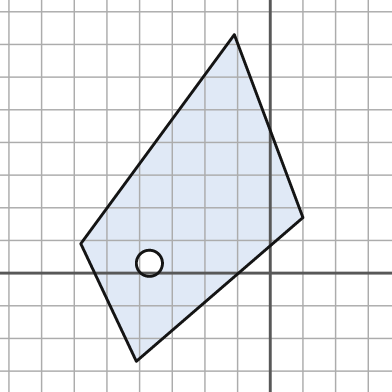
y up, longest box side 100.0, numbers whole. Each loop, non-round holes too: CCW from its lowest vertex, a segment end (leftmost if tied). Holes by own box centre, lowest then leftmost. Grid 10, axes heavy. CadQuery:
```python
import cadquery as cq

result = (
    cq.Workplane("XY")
    .moveTo(-41.0, -27.0)
    .lineTo(10.0, 17.0)
    .lineTo(-11.0, 73.0)
    .lineTo(-58.0, 9.0)
    .close()
    .moveTo(-37.0, 3.0)
    .circle(4.0)
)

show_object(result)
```